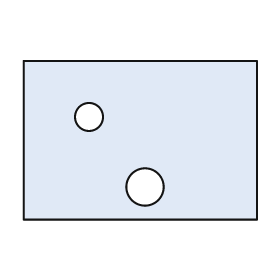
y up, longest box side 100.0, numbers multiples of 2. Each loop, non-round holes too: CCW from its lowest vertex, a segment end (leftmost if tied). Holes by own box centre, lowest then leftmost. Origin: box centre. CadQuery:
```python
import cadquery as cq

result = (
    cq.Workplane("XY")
    .moveTo(-50.0, -34.0)
    .lineTo(50.0, -34.0)
    .lineTo(50.0, 34.0)
    .lineTo(-50.0, 34.0)
    .close()
    .moveTo(2.0, -20.0)
    .circle(8.0)
    .moveTo(-22.0, 10.0)
    .circle(6.0)
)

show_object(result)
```